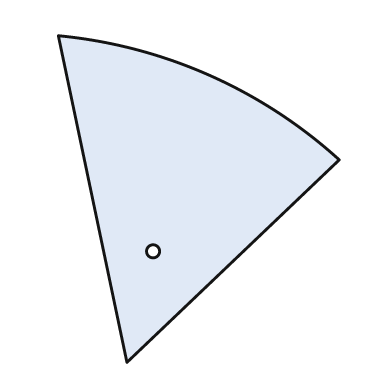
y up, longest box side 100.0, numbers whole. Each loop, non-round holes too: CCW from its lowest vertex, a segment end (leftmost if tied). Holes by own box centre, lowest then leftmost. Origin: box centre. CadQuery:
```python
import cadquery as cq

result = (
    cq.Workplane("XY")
    .moveTo(-22.0, -50.0)
    .lineTo(43.0, 12.0)
    .threePointArc((3.0, 38.0), (-43.0, 50.0))
    .close()
    .moveTo(-14.0, -16.0)
    .circle(2.0)
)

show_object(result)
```